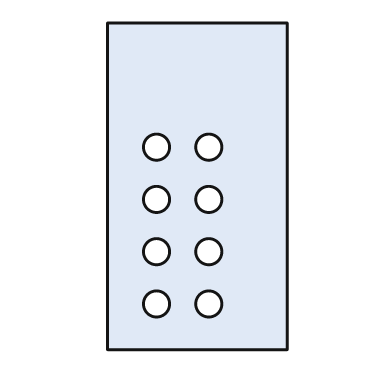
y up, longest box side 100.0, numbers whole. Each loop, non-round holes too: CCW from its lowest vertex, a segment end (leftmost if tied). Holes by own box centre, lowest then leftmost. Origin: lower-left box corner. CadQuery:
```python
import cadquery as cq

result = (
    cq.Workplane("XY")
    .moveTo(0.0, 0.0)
    .lineTo(55.0, 0.0)
    .lineTo(55.0, 100.0)
    .lineTo(0.0, 100.0)
    .close()
    .moveTo(15.0, 14.0)
    .circle(4.0)
    .moveTo(31.0, 14.0)
    .circle(4.0)
    .moveTo(15.0, 30.0)
    .circle(4.0)
    .moveTo(31.0, 30.0)
    .circle(4.0)
    .moveTo(15.0, 46.0)
    .circle(4.0)
    .moveTo(31.0, 46.0)
    .circle(4.0)
    .moveTo(15.0, 62.0)
    .circle(4.0)
    .moveTo(31.0, 62.0)
    .circle(4.0)
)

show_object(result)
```